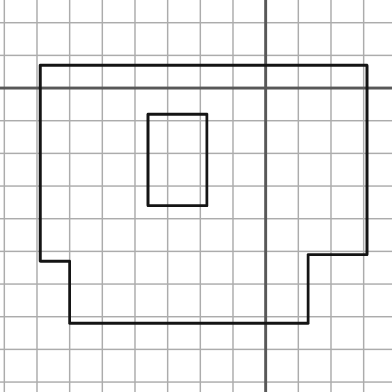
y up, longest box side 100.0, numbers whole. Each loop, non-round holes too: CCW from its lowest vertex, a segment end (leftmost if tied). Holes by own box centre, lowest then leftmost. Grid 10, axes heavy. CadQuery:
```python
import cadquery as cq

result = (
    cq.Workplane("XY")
    .moveTo(-60.0, -72.0)
    .lineTo(13.0, -72.0)
    .lineTo(13.0, -51.0)
    .lineTo(31.0, -51.0)
    .lineTo(31.0, 7.0)
    .lineTo(-69.0, 7.0)
    .lineTo(-69.0, -53.0)
    .lineTo(-60.0, -53.0)
    .close()
    .moveTo(-36.0, -36.0)
    .lineTo(-18.0, -36.0)
    .lineTo(-18.0, -8.0)
    .lineTo(-36.0, -8.0)
    .close()
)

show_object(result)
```